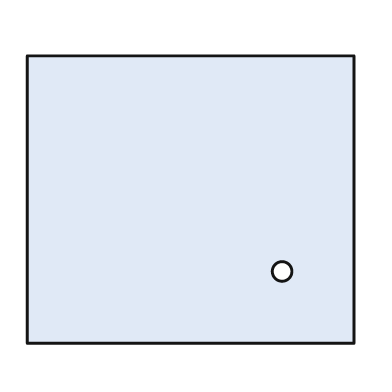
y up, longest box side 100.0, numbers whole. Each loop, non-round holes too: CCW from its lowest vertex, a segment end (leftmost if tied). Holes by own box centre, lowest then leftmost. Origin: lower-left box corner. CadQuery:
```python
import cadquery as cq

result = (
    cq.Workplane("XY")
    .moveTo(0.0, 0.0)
    .lineTo(100.0, 0.0)
    .lineTo(100.0, 88.0)
    .lineTo(0.0, 88.0)
    .close()
    .moveTo(78.0, 22.0)
    .circle(3.0)
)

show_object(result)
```